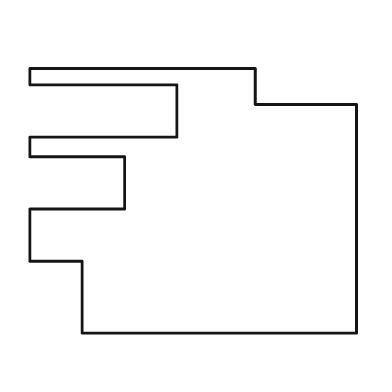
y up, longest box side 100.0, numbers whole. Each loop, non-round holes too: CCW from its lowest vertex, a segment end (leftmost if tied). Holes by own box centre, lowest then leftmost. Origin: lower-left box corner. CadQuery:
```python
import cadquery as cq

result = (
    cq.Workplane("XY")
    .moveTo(16.0, 0.0)
    .lineTo(100.0, 0.0)
    .lineTo(100.0, 70.0)
    .lineTo(69.0, 70.0)
    .lineTo(69.0, 81.0)
    .lineTo(0.0, 81.0)
    .lineTo(0.0, 76.0)
    .lineTo(45.0, 76.0)
    .lineTo(45.0, 60.0)
    .lineTo(0.0, 60.0)
    .lineTo(0.0, 54.0)
    .lineTo(29.0, 54.0)
    .lineTo(29.0, 38.0)
    .lineTo(0.0, 38.0)
    .lineTo(0.0, 22.0)
    .lineTo(16.0, 22.0)
    .close()
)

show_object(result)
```